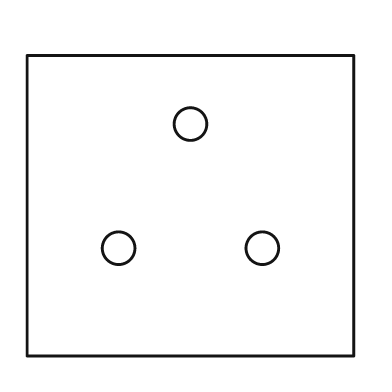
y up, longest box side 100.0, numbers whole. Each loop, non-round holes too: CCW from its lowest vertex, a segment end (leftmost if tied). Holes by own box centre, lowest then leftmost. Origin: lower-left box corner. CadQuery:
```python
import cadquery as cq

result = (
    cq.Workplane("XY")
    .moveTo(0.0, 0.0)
    .lineTo(100.0, 0.0)
    .lineTo(100.0, 92.0)
    .lineTo(0.0, 92.0)
    .close()
    .moveTo(28.0, 33.0)
    .circle(5.0)
    .moveTo(72.0, 33.0)
    .circle(5.0)
    .moveTo(50.0, 71.0)
    .circle(5.0)
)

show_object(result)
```